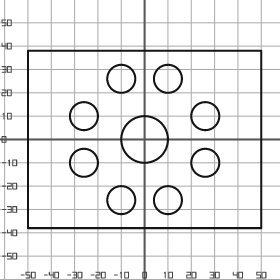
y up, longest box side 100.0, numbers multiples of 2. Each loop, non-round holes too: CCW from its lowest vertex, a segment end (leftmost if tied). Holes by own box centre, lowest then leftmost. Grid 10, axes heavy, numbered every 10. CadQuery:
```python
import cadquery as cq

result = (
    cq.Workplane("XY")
    .moveTo(-50.0, -38.0)
    .lineTo(50.0, -38.0)
    .lineTo(50.0, 38.0)
    .lineTo(-50.0, 38.0)
    .close()
    .moveTo(-10.0, -26.0)
    .circle(6.0)
    .moveTo(10.0, -26.0)
    .circle(6.0)
    .moveTo(-26.0, -10.0)
    .circle(6.0)
    .moveTo(26.0, -10.0)
    .circle(6.0)
    .moveTo(0.0, 0.0)
    .circle(10.0)
    .moveTo(-26.0, 10.0)
    .circle(6.0)
    .moveTo(26.0, 10.0)
    .circle(6.0)
    .moveTo(-10.0, 26.0)
    .circle(6.0)
    .moveTo(10.0, 26.0)
    .circle(6.0)
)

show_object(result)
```